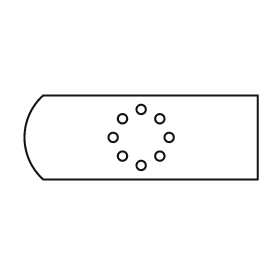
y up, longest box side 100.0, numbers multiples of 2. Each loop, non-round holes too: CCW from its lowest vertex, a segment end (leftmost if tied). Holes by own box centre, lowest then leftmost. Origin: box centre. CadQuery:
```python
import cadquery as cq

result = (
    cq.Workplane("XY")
    .moveTo(-42.0, -18.0)
    .lineTo(50.0, -18.0)
    .lineTo(50.0, 18.0)
    .lineTo(-42.0, 18.0)
    .threePointArc((-50.0, 0.0), (-42.0, -18.0))
    .close()
    .moveTo(0.0, -12.0)
    .circle(2.0)
    .moveTo(-8.0, -8.0)
    .circle(2.0)
    .moveTo(8.0, -8.0)
    .circle(2.0)
    .moveTo(-12.0, 0.0)
    .circle(2.0)
    .moveTo(12.0, 0.0)
    .circle(2.0)
    .moveTo(-8.0, 8.0)
    .circle(2.0)
    .moveTo(8.0, 8.0)
    .circle(2.0)
    .moveTo(0.0, 12.0)
    .circle(2.0)
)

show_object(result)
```